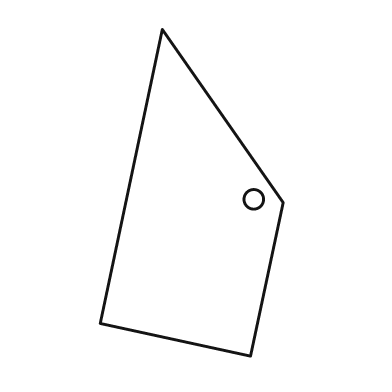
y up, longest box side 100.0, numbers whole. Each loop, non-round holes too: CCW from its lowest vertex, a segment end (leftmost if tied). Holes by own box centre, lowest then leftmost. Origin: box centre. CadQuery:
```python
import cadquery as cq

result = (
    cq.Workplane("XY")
    .moveTo(18.0, -50.0)
    .lineTo(28.0, -3.0)
    .lineTo(-9.0, 50.0)
    .lineTo(-28.0, -40.0)
    .close()
    .moveTo(19.0, -2.0)
    .circle(3.0)
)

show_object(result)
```